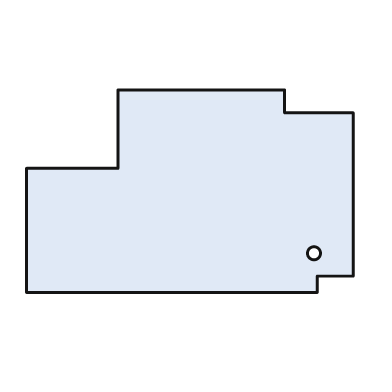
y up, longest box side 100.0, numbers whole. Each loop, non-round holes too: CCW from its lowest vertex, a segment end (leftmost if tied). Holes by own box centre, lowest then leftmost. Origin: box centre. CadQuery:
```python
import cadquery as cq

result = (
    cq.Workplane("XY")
    .moveTo(-50.0, -31.0)
    .lineTo(39.0, -31.0)
    .lineTo(39.0, -26.0)
    .lineTo(50.0, -26.0)
    .lineTo(50.0, 24.0)
    .lineTo(29.0, 24.0)
    .lineTo(29.0, 31.0)
    .lineTo(-22.0, 31.0)
    .lineTo(-22.0, 7.0)
    .lineTo(-50.0, 7.0)
    .close()
    .moveTo(38.0, -19.0)
    .circle(2.0)
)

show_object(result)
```